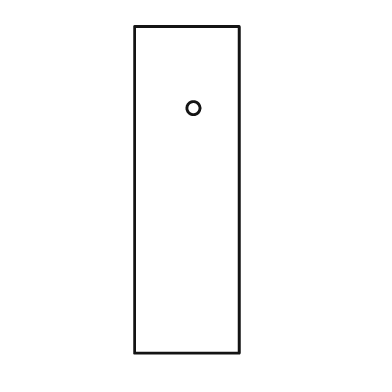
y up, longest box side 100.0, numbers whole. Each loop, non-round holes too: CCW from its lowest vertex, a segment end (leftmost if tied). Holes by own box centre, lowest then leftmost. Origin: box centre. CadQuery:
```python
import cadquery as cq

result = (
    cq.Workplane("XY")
    .moveTo(-16.0, -50.0)
    .lineTo(16.0, -50.0)
    .lineTo(16.0, 50.0)
    .lineTo(-16.0, 50.0)
    .close()
    .moveTo(2.0, 25.0)
    .circle(2.0)
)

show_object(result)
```